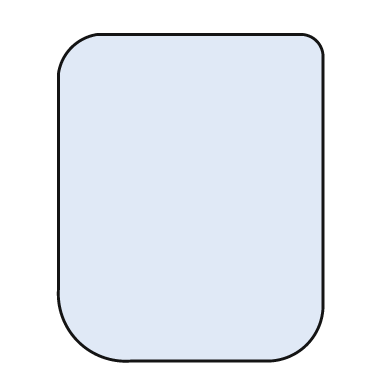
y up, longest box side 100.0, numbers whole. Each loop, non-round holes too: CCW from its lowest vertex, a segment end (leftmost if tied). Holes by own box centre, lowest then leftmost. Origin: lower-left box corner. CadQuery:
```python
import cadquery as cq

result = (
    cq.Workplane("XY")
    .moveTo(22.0, 0.0)
    .lineTo(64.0, 0.0)
    .threePointArc((76.0, 5.0), (81.0, 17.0))
    .lineTo(81.0, 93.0)
    .threePointArc((79.0, 98.0), (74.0, 100.0))
    .lineTo(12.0, 100.0)
    .threePointArc((4.0, 96.0), (0.0, 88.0))
    .lineTo(0.0, 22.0)
    .threePointArc((6.0, 6.0), (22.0, 0.0))
    .close()
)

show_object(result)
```